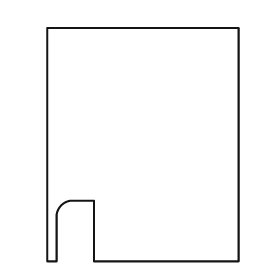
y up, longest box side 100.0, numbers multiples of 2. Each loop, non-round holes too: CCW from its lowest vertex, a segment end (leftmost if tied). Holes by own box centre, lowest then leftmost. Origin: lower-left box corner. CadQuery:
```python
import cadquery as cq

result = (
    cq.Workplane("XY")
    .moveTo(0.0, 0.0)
    .lineTo(4.0, 0.0)
    .lineTo(4.0, 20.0)
    .threePointArc((6.0, 24.0), (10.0, 26.0))
    .lineTo(20.0, 26.0)
    .lineTo(20.0, 0.0)
    .lineTo(82.0, 0.0)
    .lineTo(82.0, 100.0)
    .lineTo(0.0, 100.0)
    .close()
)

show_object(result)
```